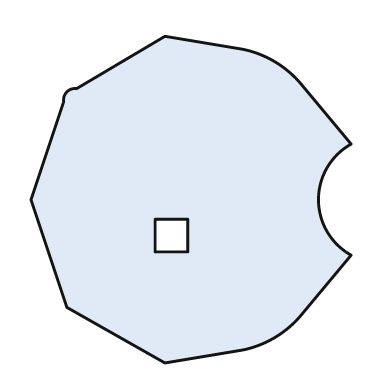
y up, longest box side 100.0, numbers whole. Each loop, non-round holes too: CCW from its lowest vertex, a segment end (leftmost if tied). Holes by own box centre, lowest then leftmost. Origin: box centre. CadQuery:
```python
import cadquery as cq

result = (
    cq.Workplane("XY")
    .moveTo(-8.0, -50.0)
    .lineTo(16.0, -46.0)
    .threePointArc((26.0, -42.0), (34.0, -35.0))
    .lineTo(49.0, -17.0)
    .threePointArc((39.0, 0.0), (49.0, 17.0))
    .lineTo(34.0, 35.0)
    .threePointArc((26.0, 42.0), (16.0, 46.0))
    .lineTo(-8.0, 50.0)
    .lineTo(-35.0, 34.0)
    .threePointArc((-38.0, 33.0), (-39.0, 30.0))
    .lineTo(-49.0, 0.0)
    .lineTo(-38.0, -33.0)
    .close()
    .moveTo(-11.0, -16.0)
    .lineTo(-1.0, -16.0)
    .lineTo(-1.0, -6.0)
    .lineTo(-11.0, -6.0)
    .close()
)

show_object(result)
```